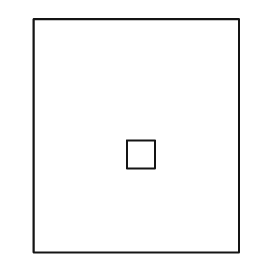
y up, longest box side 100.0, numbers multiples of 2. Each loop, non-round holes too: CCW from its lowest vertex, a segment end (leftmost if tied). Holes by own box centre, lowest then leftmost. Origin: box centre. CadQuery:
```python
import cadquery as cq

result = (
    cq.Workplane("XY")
    .moveTo(-44.0, -50.0)
    .lineTo(44.0, -50.0)
    .lineTo(44.0, 50.0)
    .lineTo(-44.0, 50.0)
    .close()
    .moveTo(-4.0, -14.0)
    .lineTo(8.0, -14.0)
    .lineTo(8.0, -2.0)
    .lineTo(-4.0, -2.0)
    .close()
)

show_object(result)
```